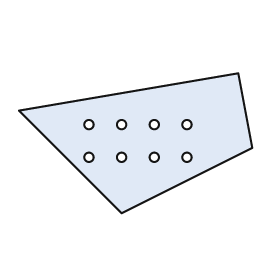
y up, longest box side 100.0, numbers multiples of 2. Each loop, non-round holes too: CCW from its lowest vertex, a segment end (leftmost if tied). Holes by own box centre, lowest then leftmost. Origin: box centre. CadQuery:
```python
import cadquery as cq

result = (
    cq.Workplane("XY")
    .moveTo(-6.0, -30.0)
    .lineTo(50.0, -2.0)
    .lineTo(44.0, 30.0)
    .lineTo(-50.0, 14.0)
    .close()
    .moveTo(-20.0, -6.0)
    .circle(2.0)
    .moveTo(-6.0, -6.0)
    .circle(2.0)
    .moveTo(8.0, -6.0)
    .circle(2.0)
    .moveTo(22.0, -6.0)
    .circle(2.0)
    .moveTo(-20.0, 8.0)
    .circle(2.0)
    .moveTo(-6.0, 8.0)
    .circle(2.0)
    .moveTo(8.0, 8.0)
    .circle(2.0)
    .moveTo(22.0, 8.0)
    .circle(2.0)
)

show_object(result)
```